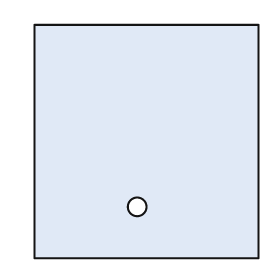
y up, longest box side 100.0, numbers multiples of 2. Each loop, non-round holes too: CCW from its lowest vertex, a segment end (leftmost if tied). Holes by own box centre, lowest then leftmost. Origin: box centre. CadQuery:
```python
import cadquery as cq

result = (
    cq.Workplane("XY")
    .moveTo(-48.0, -50.0)
    .lineTo(48.0, -50.0)
    .lineTo(48.0, 50.0)
    .lineTo(-48.0, 50.0)
    .close()
    .moveTo(-4.0, -28.0)
    .circle(4.0)
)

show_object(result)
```